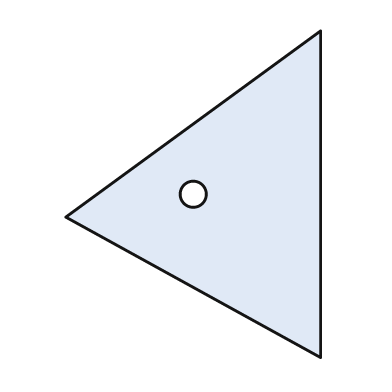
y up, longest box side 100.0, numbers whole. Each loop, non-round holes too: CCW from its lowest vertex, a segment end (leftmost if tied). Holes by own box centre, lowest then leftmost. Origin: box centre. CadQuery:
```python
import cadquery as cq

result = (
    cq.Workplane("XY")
    .moveTo(39.0, -50.0)
    .lineTo(39.0, 50.0)
    .lineTo(-39.0, -7.0)
    .close()
    .moveTo(0.0, 0.0)
    .circle(4.0)
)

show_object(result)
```